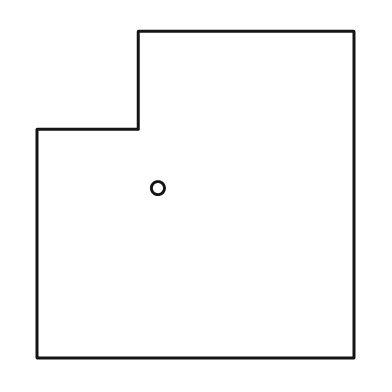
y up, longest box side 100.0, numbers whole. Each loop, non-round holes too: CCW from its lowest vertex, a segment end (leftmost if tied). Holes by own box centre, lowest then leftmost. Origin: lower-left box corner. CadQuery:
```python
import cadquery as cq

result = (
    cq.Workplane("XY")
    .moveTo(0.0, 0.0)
    .lineTo(97.0, 0.0)
    .lineTo(97.0, 100.0)
    .lineTo(31.0, 100.0)
    .lineTo(31.0, 70.0)
    .lineTo(0.0, 70.0)
    .close()
    .moveTo(37.0, 52.0)
    .circle(2.0)
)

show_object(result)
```